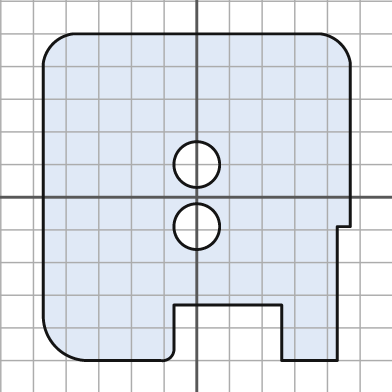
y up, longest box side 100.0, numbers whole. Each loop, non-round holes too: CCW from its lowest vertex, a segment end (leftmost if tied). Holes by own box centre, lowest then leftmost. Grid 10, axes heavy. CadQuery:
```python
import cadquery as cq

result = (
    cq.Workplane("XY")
    .moveTo(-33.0, -50.0)
    .lineTo(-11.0, -50.0)
    .threePointArc((-8.0, -49.0), (-7.0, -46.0))
    .lineTo(-7.0, -33.0)
    .lineTo(26.0, -33.0)
    .lineTo(26.0, -50.0)
    .lineTo(43.0, -50.0)
    .lineTo(43.0, -9.0)
    .lineTo(47.0, -9.0)
    .lineTo(47.0, 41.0)
    .threePointArc((44.0, 47.0), (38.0, 50.0))
    .lineTo(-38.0, 50.0)
    .threePointArc((-44.0, 47.0), (-47.0, 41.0))
    .lineTo(-47.0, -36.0)
    .threePointArc((-43.0, -46.0), (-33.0, -50.0))
    .close()
    .moveTo(0.0, -9.0)
    .circle(7.0)
    .moveTo(0.0, 10.0)
    .circle(7.0)
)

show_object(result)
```